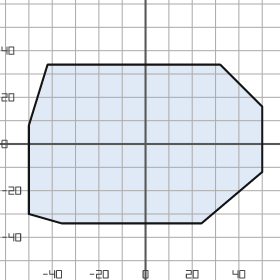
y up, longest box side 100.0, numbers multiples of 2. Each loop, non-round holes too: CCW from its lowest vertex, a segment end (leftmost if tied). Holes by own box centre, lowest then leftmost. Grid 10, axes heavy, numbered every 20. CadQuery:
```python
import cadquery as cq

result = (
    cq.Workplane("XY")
    .moveTo(-36.0, -34.0)
    .lineTo(24.0, -34.0)
    .lineTo(50.0, -12.0)
    .lineTo(50.0, 16.0)
    .lineTo(32.0, 34.0)
    .lineTo(-42.0, 34.0)
    .lineTo(-50.0, 8.0)
    .lineTo(-50.0, -30.0)
    .close()
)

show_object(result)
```